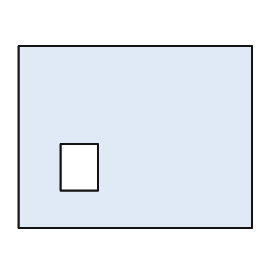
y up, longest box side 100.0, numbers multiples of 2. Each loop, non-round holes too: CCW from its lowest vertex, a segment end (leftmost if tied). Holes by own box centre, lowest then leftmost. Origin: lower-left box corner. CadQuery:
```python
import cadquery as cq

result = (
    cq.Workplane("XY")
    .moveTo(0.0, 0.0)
    .lineTo(100.0, 0.0)
    .lineTo(100.0, 78.0)
    .lineTo(0.0, 78.0)
    .close()
    .moveTo(18.0, 16.0)
    .lineTo(34.0, 16.0)
    .lineTo(34.0, 36.0)
    .lineTo(18.0, 36.0)
    .close()
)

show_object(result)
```